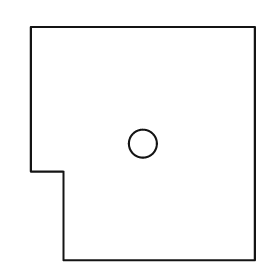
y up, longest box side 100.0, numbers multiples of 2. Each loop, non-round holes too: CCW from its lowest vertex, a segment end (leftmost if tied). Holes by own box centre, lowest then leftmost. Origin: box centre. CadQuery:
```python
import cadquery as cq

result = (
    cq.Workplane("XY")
    .moveTo(-34.0, -50.0)
    .lineTo(48.0, -50.0)
    .lineTo(48.0, 50.0)
    .lineTo(-48.0, 50.0)
    .lineTo(-48.0, -12.0)
    .lineTo(-34.0, -12.0)
    .close()
    .moveTo(0.0, 0.0)
    .circle(6.0)
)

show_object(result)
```